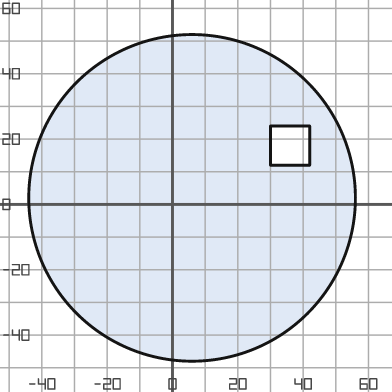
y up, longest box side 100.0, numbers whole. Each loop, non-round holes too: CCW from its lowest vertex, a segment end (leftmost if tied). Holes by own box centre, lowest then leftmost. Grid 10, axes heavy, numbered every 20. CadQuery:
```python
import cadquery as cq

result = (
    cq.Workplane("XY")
    .moveTo(6.0, 2.0)
    .circle(50.0)
    .moveTo(30.0, 12.0)
    .lineTo(42.0, 12.0)
    .lineTo(42.0, 24.0)
    .lineTo(30.0, 24.0)
    .close()
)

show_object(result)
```